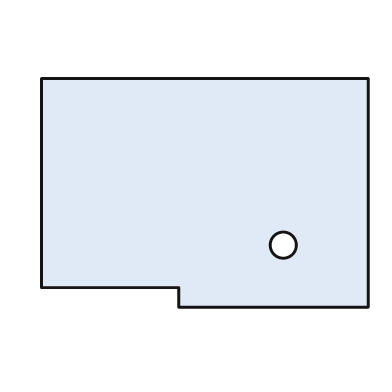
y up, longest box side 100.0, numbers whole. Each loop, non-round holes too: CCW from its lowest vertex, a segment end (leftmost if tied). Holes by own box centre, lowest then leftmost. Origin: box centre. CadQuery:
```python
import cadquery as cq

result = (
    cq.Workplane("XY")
    .moveTo(-8.0, -35.0)
    .lineTo(50.0, -35.0)
    .lineTo(50.0, 35.0)
    .lineTo(-50.0, 35.0)
    .lineTo(-50.0, -29.0)
    .lineTo(-8.0, -29.0)
    .close()
    .moveTo(24.0, -16.0)
    .circle(4.0)
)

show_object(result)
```